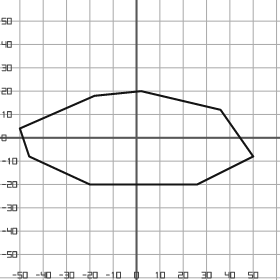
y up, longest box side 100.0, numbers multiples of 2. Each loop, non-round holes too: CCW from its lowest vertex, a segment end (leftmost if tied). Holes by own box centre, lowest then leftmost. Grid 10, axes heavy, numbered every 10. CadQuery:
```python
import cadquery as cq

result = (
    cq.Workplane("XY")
    .moveTo(-20.0, -20.0)
    .lineTo(26.0, -20.0)
    .lineTo(50.0, -8.0)
    .lineTo(36.0, 12.0)
    .lineTo(2.0, 20.0)
    .lineTo(-18.0, 18.0)
    .lineTo(-50.0, 4.0)
    .lineTo(-46.0, -8.0)
    .close()
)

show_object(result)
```